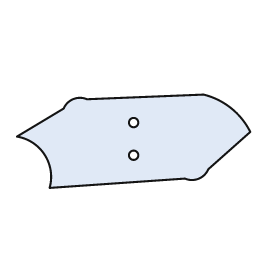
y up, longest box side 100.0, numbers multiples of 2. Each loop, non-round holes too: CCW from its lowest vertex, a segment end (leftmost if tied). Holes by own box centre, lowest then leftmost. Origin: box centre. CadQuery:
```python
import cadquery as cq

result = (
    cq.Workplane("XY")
    .moveTo(-36.0, -20.0)
    .lineTo(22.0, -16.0)
    .threePointArc((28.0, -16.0), (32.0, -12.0))
    .lineTo(50.0, 4.0)
    .threePointArc((42.0, 14.0), (30.0, 20.0))
    .lineTo(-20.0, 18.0)
    .threePointArc((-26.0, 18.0), (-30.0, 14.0))
    .lineTo(-50.0, 2.0)
    .threePointArc((-38.0, -6.0), (-36.0, -20.0))
    .close()
    .moveTo(0.0, -6.0)
    .circle(2.0)
    .moveTo(0.0, 8.0)
    .circle(2.0)
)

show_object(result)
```